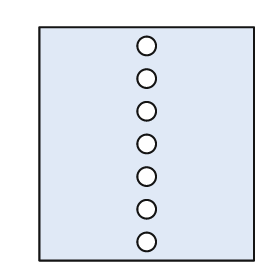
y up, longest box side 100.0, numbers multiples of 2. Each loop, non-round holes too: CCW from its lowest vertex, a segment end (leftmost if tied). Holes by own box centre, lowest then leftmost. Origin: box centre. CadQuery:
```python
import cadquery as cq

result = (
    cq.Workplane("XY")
    .moveTo(-46.0, -50.0)
    .lineTo(46.0, -50.0)
    .lineTo(46.0, 50.0)
    .lineTo(-46.0, 50.0)
    .close()
    .moveTo(0.0, -42.0)
    .circle(4.0)
    .moveTo(0.0, -28.0)
    .circle(4.0)
    .moveTo(0.0, -14.0)
    .circle(4.0)
    .moveTo(0.0, 0.0)
    .circle(4.0)
    .moveTo(0.0, 14.0)
    .circle(4.0)
    .moveTo(0.0, 28.0)
    .circle(4.0)
    .moveTo(0.0, 42.0)
    .circle(4.0)
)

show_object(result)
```